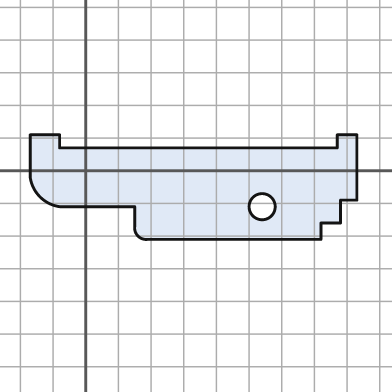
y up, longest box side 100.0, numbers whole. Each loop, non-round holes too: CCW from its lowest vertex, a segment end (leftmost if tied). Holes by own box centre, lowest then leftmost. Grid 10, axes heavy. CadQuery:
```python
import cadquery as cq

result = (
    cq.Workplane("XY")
    .moveTo(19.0, -21.0)
    .lineTo(72.0, -21.0)
    .lineTo(72.0, -16.0)
    .lineTo(78.0, -16.0)
    .lineTo(78.0, -9.0)
    .lineTo(83.0, -9.0)
    .lineTo(83.0, 11.0)
    .lineTo(77.0, 11.0)
    .lineTo(77.0, 7.0)
    .lineTo(-8.0, 7.0)
    .lineTo(-8.0, 11.0)
    .lineTo(-17.0, 11.0)
    .lineTo(-17.0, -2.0)
    .threePointArc((-14.0, -8.0), (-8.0, -11.0))
    .lineTo(15.0, -11.0)
    .lineTo(15.0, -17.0)
    .threePointArc((16.0, -20.0), (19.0, -21.0))
    .close()
    .moveTo(54.0, -11.0)
    .circle(4.0)
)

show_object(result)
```